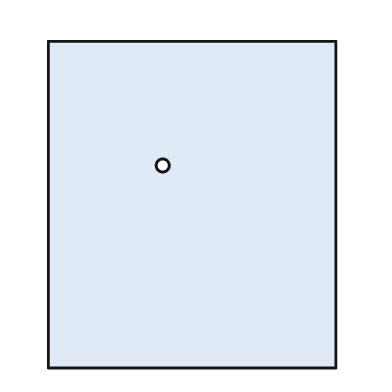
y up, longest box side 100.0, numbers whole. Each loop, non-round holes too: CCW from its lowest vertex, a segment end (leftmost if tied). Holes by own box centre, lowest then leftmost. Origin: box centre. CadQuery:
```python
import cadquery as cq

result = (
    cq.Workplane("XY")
    .moveTo(-44.0, -50.0)
    .lineTo(44.0, -50.0)
    .lineTo(44.0, 50.0)
    .lineTo(-44.0, 50.0)
    .close()
    .moveTo(-9.0, 12.0)
    .circle(2.0)
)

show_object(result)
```